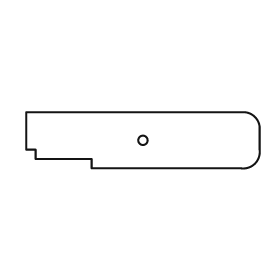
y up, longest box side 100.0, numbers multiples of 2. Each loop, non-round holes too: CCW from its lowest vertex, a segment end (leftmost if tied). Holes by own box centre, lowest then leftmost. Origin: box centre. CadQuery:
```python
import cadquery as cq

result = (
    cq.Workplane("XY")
    .moveTo(-22.0, -12.0)
    .lineTo(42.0, -12.0)
    .threePointArc((48.0, -10.0), (50.0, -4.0))
    .lineTo(50.0, 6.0)
    .threePointArc((48.0, 10.0), (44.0, 12.0))
    .lineTo(-50.0, 12.0)
    .lineTo(-50.0, -4.0)
    .lineTo(-46.0, -4.0)
    .lineTo(-46.0, -8.0)
    .lineTo(-22.0, -8.0)
    .close()
    .moveTo(0.0, 0.0)
    .circle(2.0)
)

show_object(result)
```